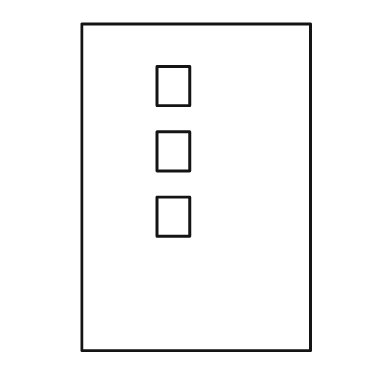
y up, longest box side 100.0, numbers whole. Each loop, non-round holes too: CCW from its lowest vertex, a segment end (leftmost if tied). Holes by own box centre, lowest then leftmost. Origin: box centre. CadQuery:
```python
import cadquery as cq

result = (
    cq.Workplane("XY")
    .moveTo(-35.0, -50.0)
    .lineTo(35.0, -50.0)
    .lineTo(35.0, 50.0)
    .lineTo(-35.0, 50.0)
    .close()
    .moveTo(-12.0, -15.0)
    .lineTo(-2.0, -15.0)
    .lineTo(-2.0, -3.0)
    .lineTo(-12.0, -3.0)
    .close()
    .moveTo(-12.0, 5.0)
    .lineTo(-2.0, 5.0)
    .lineTo(-2.0, 17.0)
    .lineTo(-12.0, 17.0)
    .close()
    .moveTo(-12.0, 25.0)
    .lineTo(-2.0, 25.0)
    .lineTo(-2.0, 37.0)
    .lineTo(-12.0, 37.0)
    .close()
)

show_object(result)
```